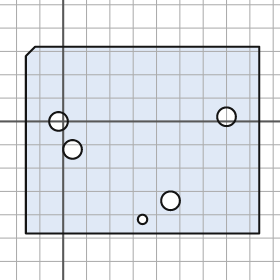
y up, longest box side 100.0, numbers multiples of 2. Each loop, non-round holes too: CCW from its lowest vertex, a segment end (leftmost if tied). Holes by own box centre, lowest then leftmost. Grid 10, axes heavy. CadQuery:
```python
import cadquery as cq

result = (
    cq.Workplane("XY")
    .moveTo(-16.0, -48.0)
    .lineTo(84.0, -48.0)
    .lineTo(84.0, 32.0)
    .lineTo(-12.0, 32.0)
    .lineTo(-16.0, 28.0)
    .close()
    .moveTo(34.0, -42.0)
    .circle(2.0)
    .moveTo(46.0, -34.0)
    .circle(4.0)
    .moveTo(4.0, -12.0)
    .circle(4.0)
    .moveTo(-2.0, 0.0)
    .circle(4.0)
    .moveTo(70.0, 2.0)
    .circle(4.0)
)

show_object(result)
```